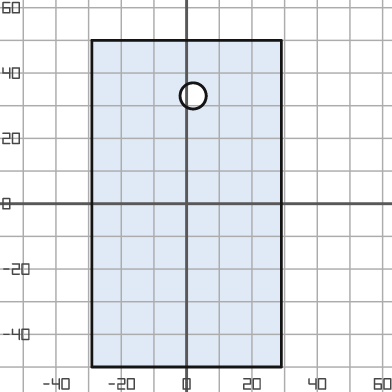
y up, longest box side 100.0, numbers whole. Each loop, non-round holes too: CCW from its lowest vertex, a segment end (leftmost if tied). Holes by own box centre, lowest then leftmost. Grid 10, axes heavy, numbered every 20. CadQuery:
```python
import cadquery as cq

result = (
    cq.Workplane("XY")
    .moveTo(-29.0, -50.0)
    .lineTo(29.0, -50.0)
    .lineTo(29.0, 50.0)
    .lineTo(-29.0, 50.0)
    .close()
    .moveTo(2.0, 33.0)
    .circle(4.0)
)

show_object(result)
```